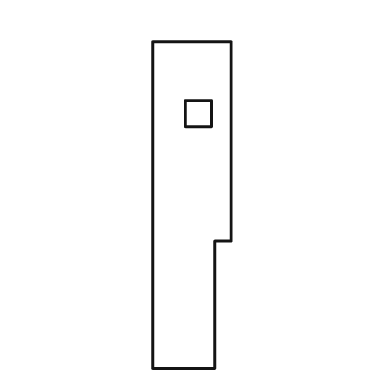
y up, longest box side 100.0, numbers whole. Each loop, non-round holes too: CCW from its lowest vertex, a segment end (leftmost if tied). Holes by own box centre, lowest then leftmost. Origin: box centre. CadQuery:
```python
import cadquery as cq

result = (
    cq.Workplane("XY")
    .moveTo(-12.0, -50.0)
    .lineTo(7.0, -50.0)
    .lineTo(7.0, -11.0)
    .lineTo(12.0, -11.0)
    .lineTo(12.0, 50.0)
    .lineTo(-12.0, 50.0)
    .close()
    .moveTo(-2.0, 24.0)
    .lineTo(6.0, 24.0)
    .lineTo(6.0, 32.0)
    .lineTo(-2.0, 32.0)
    .close()
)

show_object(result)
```